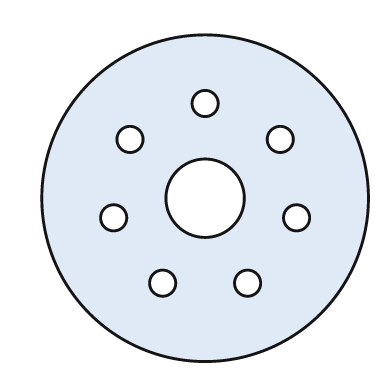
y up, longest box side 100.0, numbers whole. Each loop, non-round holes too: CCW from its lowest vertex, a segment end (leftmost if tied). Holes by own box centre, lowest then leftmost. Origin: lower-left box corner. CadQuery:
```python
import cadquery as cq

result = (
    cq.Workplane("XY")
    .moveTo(50.0, 50.0)
    .circle(50.0)
    .moveTo(37.0, 24.0)
    .circle(4.0)
    .moveTo(63.0, 24.0)
    .circle(4.0)
    .moveTo(22.0, 44.0)
    .circle(4.0)
    .moveTo(78.0, 44.0)
    .circle(4.0)
    .moveTo(50.0, 50.0)
    .circle(12.0)
    .moveTo(27.0, 68.0)
    .circle(4.0)
    .moveTo(73.0, 68.0)
    .circle(4.0)
    .moveTo(50.0, 79.0)
    .circle(4.0)
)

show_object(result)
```